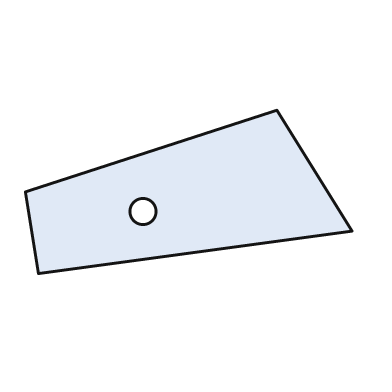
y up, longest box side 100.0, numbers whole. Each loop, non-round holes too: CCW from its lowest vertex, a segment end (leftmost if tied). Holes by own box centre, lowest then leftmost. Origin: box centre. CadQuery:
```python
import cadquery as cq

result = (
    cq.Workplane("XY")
    .moveTo(-46.0, -25.0)
    .lineTo(50.0, -12.0)
    .lineTo(27.0, 25.0)
    .lineTo(-50.0, 0.0)
    .close()
    .moveTo(-14.0, -6.0)
    .circle(4.0)
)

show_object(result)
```